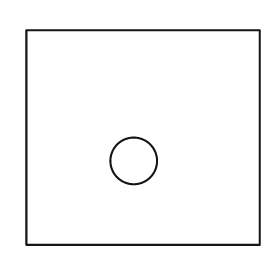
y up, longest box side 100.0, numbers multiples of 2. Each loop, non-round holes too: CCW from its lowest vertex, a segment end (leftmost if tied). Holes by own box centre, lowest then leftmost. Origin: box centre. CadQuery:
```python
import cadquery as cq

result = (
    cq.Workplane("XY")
    .moveTo(-50.0, -46.0)
    .lineTo(50.0, -46.0)
    .lineTo(50.0, 46.0)
    .lineTo(-50.0, 46.0)
    .close()
    .moveTo(-4.0, -10.0)
    .circle(10.0)
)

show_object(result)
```